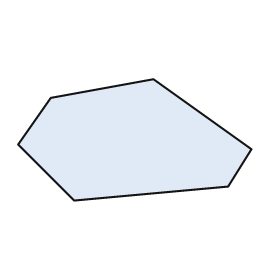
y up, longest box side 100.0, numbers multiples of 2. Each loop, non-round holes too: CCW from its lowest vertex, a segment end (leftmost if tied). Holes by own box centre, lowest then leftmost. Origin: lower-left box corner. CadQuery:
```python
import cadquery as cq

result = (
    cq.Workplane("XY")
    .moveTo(24.0, 0.0)
    .lineTo(90.0, 6.0)
    .lineTo(100.0, 22.0)
    .lineTo(58.0, 52.0)
    .lineTo(14.0, 44.0)
    .lineTo(0.0, 24.0)
    .close()
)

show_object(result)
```